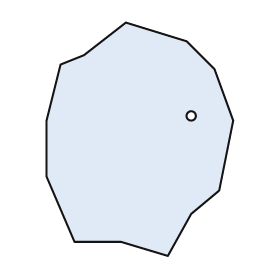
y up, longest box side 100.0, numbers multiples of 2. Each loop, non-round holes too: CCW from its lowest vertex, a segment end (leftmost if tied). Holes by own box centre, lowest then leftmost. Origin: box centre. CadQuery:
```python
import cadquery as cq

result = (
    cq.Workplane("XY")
    .moveTo(12.0, -50.0)
    .lineTo(22.0, -32.0)
    .lineTo(34.0, -22.0)
    .lineTo(40.0, 8.0)
    .lineTo(32.0, 30.0)
    .lineTo(20.0, 42.0)
    .lineTo(-6.0, 50.0)
    .lineTo(-24.0, 36.0)
    .lineTo(-34.0, 32.0)
    .lineTo(-40.0, 8.0)
    .lineTo(-40.0, -16.0)
    .lineTo(-28.0, -44.0)
    .lineTo(-8.0, -44.0)
    .close()
    .moveTo(22.0, 10.0)
    .circle(2.0)
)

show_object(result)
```